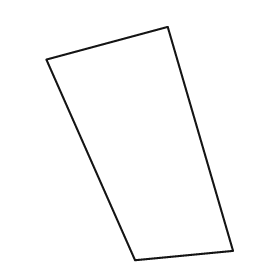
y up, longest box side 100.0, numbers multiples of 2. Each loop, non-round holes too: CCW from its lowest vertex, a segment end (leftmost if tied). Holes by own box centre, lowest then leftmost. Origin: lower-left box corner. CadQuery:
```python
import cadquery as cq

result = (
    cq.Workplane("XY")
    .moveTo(38.0, 0.0)
    .lineTo(80.0, 4.0)
    .lineTo(52.0, 100.0)
    .lineTo(0.0, 86.0)
    .close()
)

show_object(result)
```